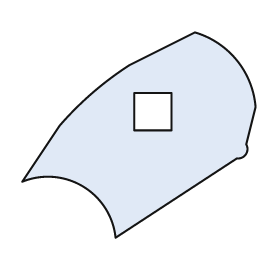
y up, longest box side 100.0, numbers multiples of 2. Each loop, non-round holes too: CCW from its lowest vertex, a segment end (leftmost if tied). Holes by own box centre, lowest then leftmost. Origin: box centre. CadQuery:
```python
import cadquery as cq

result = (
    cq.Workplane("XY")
    .moveTo(-10.0, -44.0)
    .lineTo(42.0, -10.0)
    .threePointArc((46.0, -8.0), (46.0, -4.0))
    .lineTo(50.0, 12.0)
    .threePointArc((42.0, 32.0), (24.0, 44.0))
    .lineTo(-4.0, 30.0)
    .threePointArc((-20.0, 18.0), (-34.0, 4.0))
    .lineTo(-50.0, -20.0)
    .threePointArc((-24.0, -22.0), (-10.0, -44.0))
    .close()
    .moveTo(-2.0, 2.0)
    .lineTo(14.0, 2.0)
    .lineTo(14.0, 18.0)
    .lineTo(-2.0, 18.0)
    .close()
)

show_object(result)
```